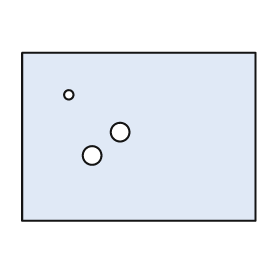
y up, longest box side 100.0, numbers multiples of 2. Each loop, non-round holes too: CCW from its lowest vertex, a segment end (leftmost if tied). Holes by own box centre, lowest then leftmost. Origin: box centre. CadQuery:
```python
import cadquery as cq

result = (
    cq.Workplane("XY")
    .moveTo(-50.0, -36.0)
    .lineTo(50.0, -36.0)
    .lineTo(50.0, 36.0)
    .lineTo(-50.0, 36.0)
    .close()
    .moveTo(-20.0, -8.0)
    .circle(4.0)
    .moveTo(-8.0, 2.0)
    .circle(4.0)
    .moveTo(-30.0, 18.0)
    .circle(2.0)
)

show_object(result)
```